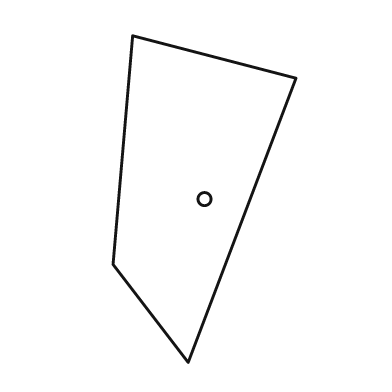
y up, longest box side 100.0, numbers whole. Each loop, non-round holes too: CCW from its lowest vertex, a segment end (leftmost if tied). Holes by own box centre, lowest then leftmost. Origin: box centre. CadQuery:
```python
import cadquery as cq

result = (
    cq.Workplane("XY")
    .moveTo(-5.0, -50.0)
    .lineTo(28.0, 37.0)
    .lineTo(-22.0, 50.0)
    .lineTo(-28.0, -20.0)
    .close()
    .moveTo(0.0, 0.0)
    .circle(2.0)
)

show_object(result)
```